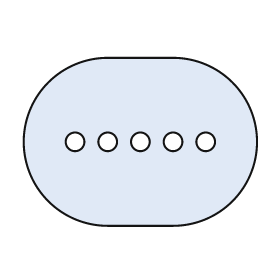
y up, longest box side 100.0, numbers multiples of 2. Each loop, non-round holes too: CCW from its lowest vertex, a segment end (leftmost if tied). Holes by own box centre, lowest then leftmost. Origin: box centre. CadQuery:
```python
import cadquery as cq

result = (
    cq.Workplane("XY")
    .moveTo(-14.0, -36.0)
    .lineTo(14.0, -36.0)
    .threePointArc((50.0, 0.0), (14.0, 36.0))
    .lineTo(-14.0, 36.0)
    .threePointArc((-50.0, 0.0), (-14.0, -36.0))
    .close()
    .moveTo(-28.0, 0.0)
    .circle(4.0)
    .moveTo(-14.0, 0.0)
    .circle(4.0)
    .moveTo(0.0, 0.0)
    .circle(4.0)
    .moveTo(14.0, 0.0)
    .circle(4.0)
    .moveTo(28.0, 0.0)
    .circle(4.0)
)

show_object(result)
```